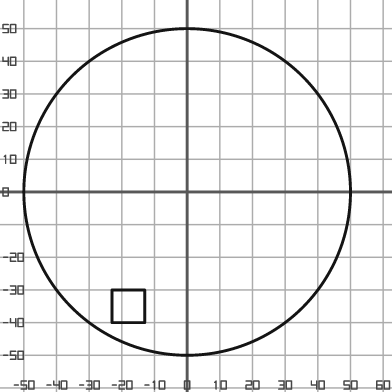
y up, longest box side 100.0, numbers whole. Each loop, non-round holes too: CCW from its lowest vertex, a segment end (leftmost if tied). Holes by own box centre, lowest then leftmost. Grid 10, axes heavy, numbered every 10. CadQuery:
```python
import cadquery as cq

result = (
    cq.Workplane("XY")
    .moveTo(0.0, 0.0)
    .circle(50.0)
    .moveTo(-23.0, -40.0)
    .lineTo(-13.0, -40.0)
    .lineTo(-13.0, -30.0)
    .lineTo(-23.0, -30.0)
    .close()
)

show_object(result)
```